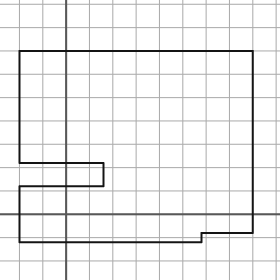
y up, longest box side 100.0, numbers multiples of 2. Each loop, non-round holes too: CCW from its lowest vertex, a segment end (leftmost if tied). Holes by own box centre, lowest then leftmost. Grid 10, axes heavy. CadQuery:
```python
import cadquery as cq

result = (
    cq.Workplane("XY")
    .moveTo(-20.0, -12.0)
    .lineTo(58.0, -12.0)
    .lineTo(58.0, -8.0)
    .lineTo(80.0, -8.0)
    .lineTo(80.0, 70.0)
    .lineTo(-20.0, 70.0)
    .lineTo(-20.0, 22.0)
    .lineTo(16.0, 22.0)
    .lineTo(16.0, 12.0)
    .lineTo(-20.0, 12.0)
    .close()
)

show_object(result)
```